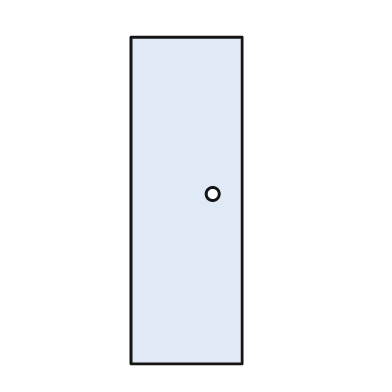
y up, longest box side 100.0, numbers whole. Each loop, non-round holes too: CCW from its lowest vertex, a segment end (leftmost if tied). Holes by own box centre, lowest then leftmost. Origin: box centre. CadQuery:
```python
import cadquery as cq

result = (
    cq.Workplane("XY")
    .moveTo(-17.0, -50.0)
    .lineTo(17.0, -50.0)
    .lineTo(17.0, 50.0)
    .lineTo(-17.0, 50.0)
    .close()
    .moveTo(8.0, 2.0)
    .circle(2.0)
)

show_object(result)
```